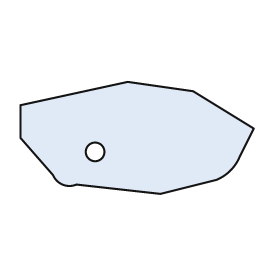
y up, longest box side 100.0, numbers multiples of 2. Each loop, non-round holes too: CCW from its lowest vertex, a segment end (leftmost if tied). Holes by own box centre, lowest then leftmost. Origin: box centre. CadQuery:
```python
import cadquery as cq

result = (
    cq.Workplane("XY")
    .moveTo(10.0, -24.0)
    .lineTo(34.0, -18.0)
    .threePointArc((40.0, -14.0), (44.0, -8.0))
    .lineTo(50.0, 4.0)
    .lineTo(24.0, 20.0)
    .lineTo(-4.0, 24.0)
    .lineTo(-50.0, 14.0)
    .lineTo(-50.0, 0.0)
    .lineTo(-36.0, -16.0)
    .threePointArc((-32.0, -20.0), (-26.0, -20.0))
    .close()
    .moveTo(-18.0, -6.0)
    .circle(4.0)
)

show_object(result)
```